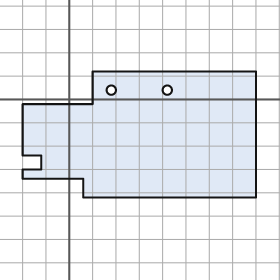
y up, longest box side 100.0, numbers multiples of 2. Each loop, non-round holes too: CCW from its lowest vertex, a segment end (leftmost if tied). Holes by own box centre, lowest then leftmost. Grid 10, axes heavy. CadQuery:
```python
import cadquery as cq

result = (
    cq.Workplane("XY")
    .moveTo(6.0, -42.0)
    .lineTo(80.0, -42.0)
    .lineTo(80.0, 12.0)
    .lineTo(10.0, 12.0)
    .lineTo(10.0, -2.0)
    .lineTo(-20.0, -2.0)
    .lineTo(-20.0, -24.0)
    .lineTo(-12.0, -24.0)
    .lineTo(-12.0, -30.0)
    .lineTo(-20.0, -30.0)
    .lineTo(-20.0, -34.0)
    .lineTo(6.0, -34.0)
    .close()
    .moveTo(18.0, 4.0)
    .circle(2.0)
    .moveTo(42.0, 4.0)
    .circle(2.0)
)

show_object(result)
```